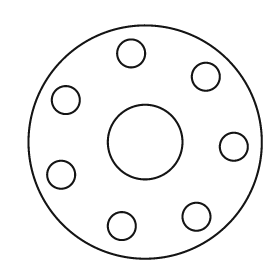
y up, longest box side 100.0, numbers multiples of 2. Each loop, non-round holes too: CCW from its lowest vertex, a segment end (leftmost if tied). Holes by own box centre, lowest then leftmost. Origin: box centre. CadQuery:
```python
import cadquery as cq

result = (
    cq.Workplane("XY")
    .moveTo(0.0, 0.0)
    .circle(50.0)
    .moveTo(-10.0, -36.0)
    .circle(6.0)
    .moveTo(22.0, -32.0)
    .circle(6.0)
    .moveTo(-36.0, -14.0)
    .circle(6.0)
    .moveTo(38.0, -2.0)
    .circle(6.0)
    .moveTo(0.0, 0.0)
    .circle(16.0)
    .moveTo(-34.0, 18.0)
    .circle(6.0)
    .moveTo(26.0, 28.0)
    .circle(6.0)
    .moveTo(-6.0, 38.0)
    .circle(6.0)
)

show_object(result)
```